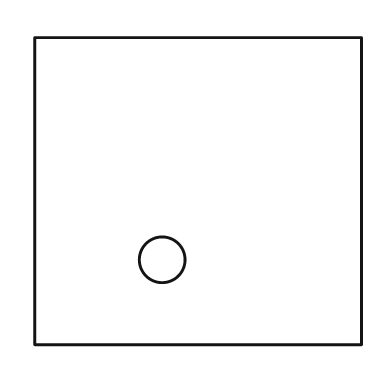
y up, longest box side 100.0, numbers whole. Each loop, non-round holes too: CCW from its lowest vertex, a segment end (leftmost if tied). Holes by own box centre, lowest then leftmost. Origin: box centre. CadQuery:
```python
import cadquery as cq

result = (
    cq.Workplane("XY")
    .moveTo(-50.0, -47.0)
    .lineTo(50.0, -47.0)
    .lineTo(50.0, 47.0)
    .lineTo(-50.0, 47.0)
    .close()
    .moveTo(-11.0, -21.0)
    .circle(7.0)
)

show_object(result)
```